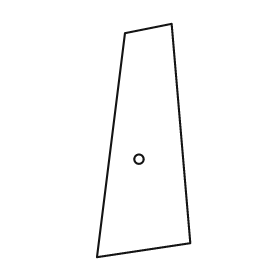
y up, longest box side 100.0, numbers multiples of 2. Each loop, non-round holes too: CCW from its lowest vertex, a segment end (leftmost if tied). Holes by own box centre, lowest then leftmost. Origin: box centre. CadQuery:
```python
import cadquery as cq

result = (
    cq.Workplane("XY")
    .moveTo(-20.0, -50.0)
    .lineTo(20.0, -44.0)
    .lineTo(12.0, 50.0)
    .lineTo(-8.0, 46.0)
    .close()
    .moveTo(-2.0, -8.0)
    .circle(2.0)
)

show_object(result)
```